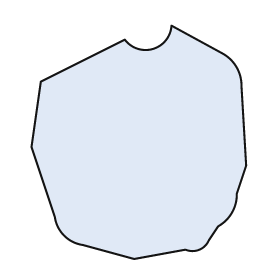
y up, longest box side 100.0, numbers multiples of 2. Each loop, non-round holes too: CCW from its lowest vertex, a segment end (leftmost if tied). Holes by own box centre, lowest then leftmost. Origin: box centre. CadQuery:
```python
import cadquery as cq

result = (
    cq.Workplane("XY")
    .moveTo(-2.0, -50.0)
    .lineTo(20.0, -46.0)
    .threePointArc((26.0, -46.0), (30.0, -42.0))
    .lineTo(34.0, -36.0)
    .threePointArc((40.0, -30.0), (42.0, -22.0))
    .lineTo(46.0, -10.0)
    .lineTo(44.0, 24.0)
    .threePointArc((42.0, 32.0), (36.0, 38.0))
    .lineTo(14.0, 50.0)
    .threePointArc((6.0, 40.0), (-6.0, 44.0))
    .lineTo(-42.0, 26.0)
    .lineTo(-46.0, -2.0)
    .lineTo(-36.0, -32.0)
    .threePointArc((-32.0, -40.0), (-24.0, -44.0))
    .close()
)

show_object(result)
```